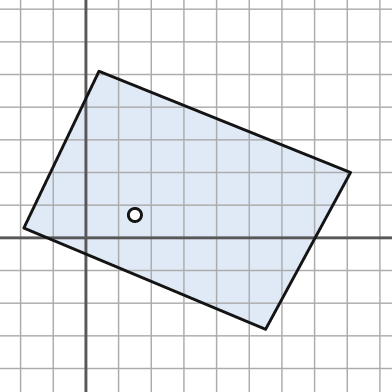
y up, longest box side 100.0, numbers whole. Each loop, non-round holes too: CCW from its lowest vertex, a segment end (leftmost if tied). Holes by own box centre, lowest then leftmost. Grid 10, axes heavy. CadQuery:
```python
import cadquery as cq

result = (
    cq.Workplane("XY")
    .moveTo(55.0, -28.0)
    .lineTo(81.0, 20.0)
    .lineTo(4.0, 51.0)
    .lineTo(-19.0, 3.0)
    .close()
    .moveTo(15.0, 7.0)
    .circle(2.0)
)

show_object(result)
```